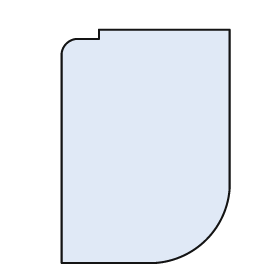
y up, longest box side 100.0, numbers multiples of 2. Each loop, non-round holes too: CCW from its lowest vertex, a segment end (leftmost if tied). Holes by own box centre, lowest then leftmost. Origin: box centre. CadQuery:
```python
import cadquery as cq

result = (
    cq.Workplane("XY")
    .moveTo(-36.0, -50.0)
    .lineTo(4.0, -50.0)
    .threePointArc((26.0, -40.0), (36.0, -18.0))
    .lineTo(36.0, 50.0)
    .lineTo(-20.0, 50.0)
    .lineTo(-20.0, 46.0)
    .lineTo(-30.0, 46.0)
    .threePointArc((-34.0, 44.0), (-36.0, 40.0))
    .close()
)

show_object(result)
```